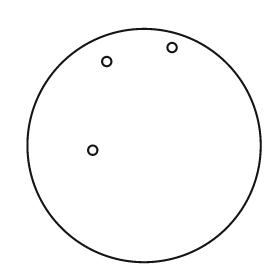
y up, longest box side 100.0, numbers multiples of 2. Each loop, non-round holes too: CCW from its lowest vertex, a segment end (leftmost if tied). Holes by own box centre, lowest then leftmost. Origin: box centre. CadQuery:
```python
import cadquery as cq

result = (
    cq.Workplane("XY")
    .moveTo(0.0, 0.0)
    .circle(50.0)
    .moveTo(-22.0, -2.0)
    .circle(2.0)
    .moveTo(-16.0, 36.0)
    .circle(2.0)
    .moveTo(12.0, 42.0)
    .circle(2.0)
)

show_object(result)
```